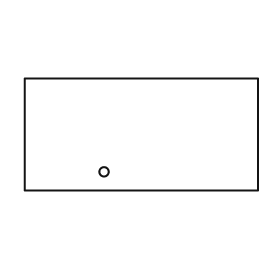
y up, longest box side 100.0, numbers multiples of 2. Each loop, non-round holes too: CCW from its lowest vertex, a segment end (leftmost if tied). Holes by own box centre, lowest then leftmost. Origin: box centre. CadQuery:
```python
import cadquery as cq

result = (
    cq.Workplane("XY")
    .moveTo(-50.0, -24.0)
    .lineTo(50.0, -24.0)
    .lineTo(50.0, 24.0)
    .lineTo(-50.0, 24.0)
    .close()
    .moveTo(-16.0, -16.0)
    .circle(2.0)
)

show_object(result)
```